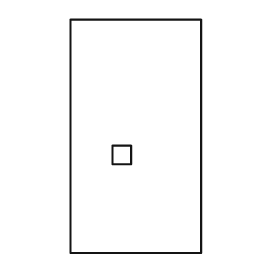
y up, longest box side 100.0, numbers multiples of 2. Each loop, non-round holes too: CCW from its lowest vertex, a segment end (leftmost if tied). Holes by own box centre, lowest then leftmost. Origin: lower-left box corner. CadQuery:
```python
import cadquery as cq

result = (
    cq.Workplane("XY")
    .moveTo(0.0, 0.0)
    .lineTo(56.0, 0.0)
    .lineTo(56.0, 100.0)
    .lineTo(0.0, 100.0)
    .close()
    .moveTo(18.0, 38.0)
    .lineTo(26.0, 38.0)
    .lineTo(26.0, 46.0)
    .lineTo(18.0, 46.0)
    .close()
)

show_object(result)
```